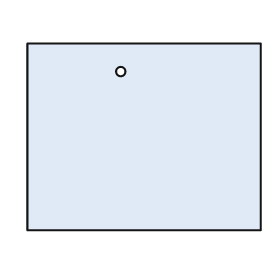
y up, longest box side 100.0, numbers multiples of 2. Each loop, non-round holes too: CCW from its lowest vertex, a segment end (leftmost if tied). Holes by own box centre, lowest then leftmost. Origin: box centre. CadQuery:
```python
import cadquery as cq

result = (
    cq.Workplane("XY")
    .moveTo(-50.0, -40.0)
    .lineTo(50.0, -40.0)
    .lineTo(50.0, 40.0)
    .lineTo(-50.0, 40.0)
    .close()
    .moveTo(-10.0, 28.0)
    .circle(2.0)
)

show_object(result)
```